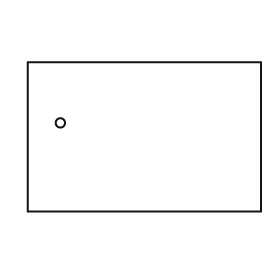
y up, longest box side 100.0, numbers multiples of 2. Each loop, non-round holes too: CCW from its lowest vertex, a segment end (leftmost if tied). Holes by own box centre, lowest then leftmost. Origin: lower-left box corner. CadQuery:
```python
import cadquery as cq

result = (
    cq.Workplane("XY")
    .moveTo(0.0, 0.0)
    .lineTo(100.0, 0.0)
    .lineTo(100.0, 64.0)
    .lineTo(0.0, 64.0)
    .close()
    .moveTo(14.0, 38.0)
    .circle(2.0)
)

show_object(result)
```